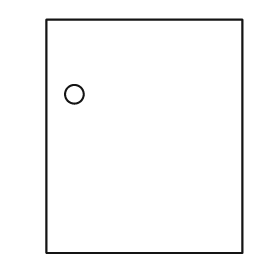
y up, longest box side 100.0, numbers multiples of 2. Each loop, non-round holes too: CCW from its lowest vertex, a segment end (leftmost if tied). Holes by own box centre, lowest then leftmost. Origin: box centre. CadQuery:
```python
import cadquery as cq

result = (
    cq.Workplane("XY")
    .moveTo(-42.0, -50.0)
    .lineTo(42.0, -50.0)
    .lineTo(42.0, 50.0)
    .lineTo(-42.0, 50.0)
    .close()
    .moveTo(-30.0, 18.0)
    .circle(4.0)
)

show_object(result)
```